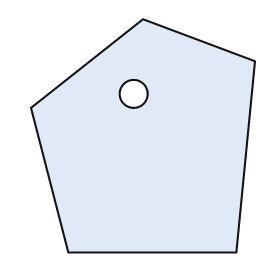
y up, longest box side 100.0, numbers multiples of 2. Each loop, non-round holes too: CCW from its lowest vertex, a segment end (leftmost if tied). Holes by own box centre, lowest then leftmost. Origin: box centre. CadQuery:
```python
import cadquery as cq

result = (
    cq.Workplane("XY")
    .moveTo(-32.0, -50.0)
    .lineTo(40.0, -50.0)
    .lineTo(48.0, 32.0)
    .lineTo(0.0, 50.0)
    .lineTo(-48.0, 12.0)
    .close()
    .moveTo(-4.0, 18.0)
    .circle(6.0)
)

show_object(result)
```